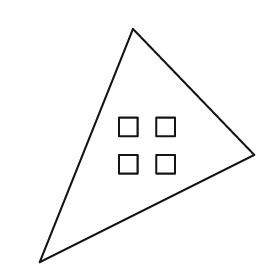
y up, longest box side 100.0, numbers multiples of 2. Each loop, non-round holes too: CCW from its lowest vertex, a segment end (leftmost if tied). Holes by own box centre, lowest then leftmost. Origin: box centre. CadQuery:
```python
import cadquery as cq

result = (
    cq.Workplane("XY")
    .moveTo(-46.0, -50.0)
    .lineTo(46.0, -4.0)
    .lineTo(-6.0, 50.0)
    .close()
    .moveTo(-12.0, -12.0)
    .lineTo(-4.0, -12.0)
    .lineTo(-4.0, -4.0)
    .lineTo(-12.0, -4.0)
    .close()
    .moveTo(4.0, -12.0)
    .lineTo(12.0, -12.0)
    .lineTo(12.0, -4.0)
    .lineTo(4.0, -4.0)
    .close()
    .moveTo(-12.0, 4.0)
    .lineTo(-4.0, 4.0)
    .lineTo(-4.0, 12.0)
    .lineTo(-12.0, 12.0)
    .close()
    .moveTo(4.0, 4.0)
    .lineTo(12.0, 4.0)
    .lineTo(12.0, 12.0)
    .lineTo(4.0, 12.0)
    .close()
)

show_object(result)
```